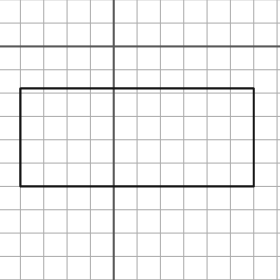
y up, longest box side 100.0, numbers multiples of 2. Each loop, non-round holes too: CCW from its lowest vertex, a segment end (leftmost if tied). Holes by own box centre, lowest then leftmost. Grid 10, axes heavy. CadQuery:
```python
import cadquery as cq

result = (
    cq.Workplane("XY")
    .moveTo(-40.0, -60.0)
    .lineTo(60.0, -60.0)
    .lineTo(60.0, -18.0)
    .lineTo(-40.0, -18.0)
    .close()
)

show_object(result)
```